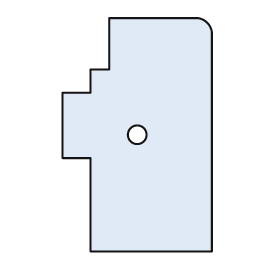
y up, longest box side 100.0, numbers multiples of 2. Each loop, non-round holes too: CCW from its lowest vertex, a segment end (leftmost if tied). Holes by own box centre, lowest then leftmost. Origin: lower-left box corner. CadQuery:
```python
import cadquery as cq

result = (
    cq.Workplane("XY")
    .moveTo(12.0, 0.0)
    .lineTo(64.0, 0.0)
    .lineTo(64.0, 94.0)
    .threePointArc((62.0, 98.0), (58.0, 100.0))
    .lineTo(20.0, 100.0)
    .lineTo(20.0, 78.0)
    .lineTo(12.0, 78.0)
    .lineTo(12.0, 68.0)
    .lineTo(0.0, 68.0)
    .lineTo(0.0, 40.0)
    .lineTo(12.0, 40.0)
    .close()
    .moveTo(32.0, 50.0)
    .circle(4.0)
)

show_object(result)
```